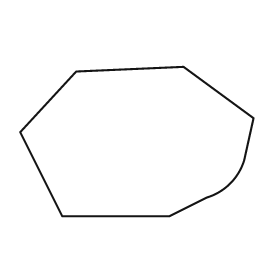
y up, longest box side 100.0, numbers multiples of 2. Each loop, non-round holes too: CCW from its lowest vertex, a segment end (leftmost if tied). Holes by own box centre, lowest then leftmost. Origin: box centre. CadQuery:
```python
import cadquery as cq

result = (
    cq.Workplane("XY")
    .moveTo(-32.0, -32.0)
    .lineTo(14.0, -32.0)
    .lineTo(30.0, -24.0)
    .threePointArc((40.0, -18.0), (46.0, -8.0))
    .lineTo(50.0, 10.0)
    .lineTo(20.0, 32.0)
    .lineTo(-26.0, 30.0)
    .lineTo(-50.0, 4.0)
    .close()
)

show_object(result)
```